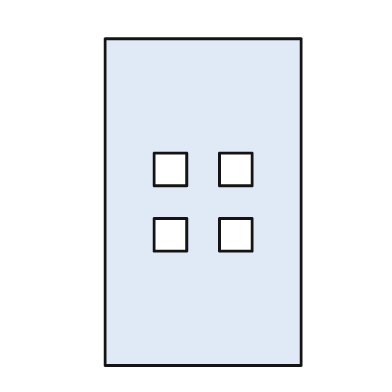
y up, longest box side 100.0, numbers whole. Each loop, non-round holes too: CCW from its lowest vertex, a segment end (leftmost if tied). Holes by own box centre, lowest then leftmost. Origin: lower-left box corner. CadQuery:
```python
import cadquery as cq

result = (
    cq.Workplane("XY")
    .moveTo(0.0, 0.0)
    .lineTo(60.0, 0.0)
    .lineTo(60.0, 100.0)
    .lineTo(0.0, 100.0)
    .close()
    .moveTo(15.0, 35.0)
    .lineTo(25.0, 35.0)
    .lineTo(25.0, 45.0)
    .lineTo(15.0, 45.0)
    .close()
    .moveTo(35.0, 35.0)
    .lineTo(45.0, 35.0)
    .lineTo(45.0, 45.0)
    .lineTo(35.0, 45.0)
    .close()
    .moveTo(15.0, 55.0)
    .lineTo(25.0, 55.0)
    .lineTo(25.0, 65.0)
    .lineTo(15.0, 65.0)
    .close()
    .moveTo(35.0, 55.0)
    .lineTo(45.0, 55.0)
    .lineTo(45.0, 65.0)
    .lineTo(35.0, 65.0)
    .close()
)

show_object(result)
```